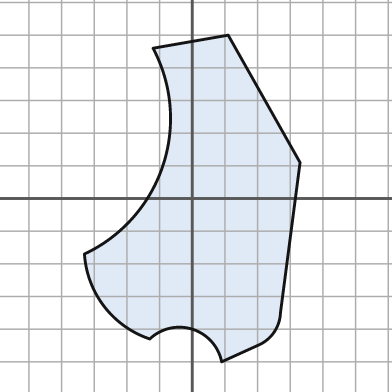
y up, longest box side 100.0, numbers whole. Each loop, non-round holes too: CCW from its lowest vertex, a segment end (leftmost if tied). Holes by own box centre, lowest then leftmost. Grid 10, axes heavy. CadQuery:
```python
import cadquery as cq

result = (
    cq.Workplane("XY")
    .moveTo(9.0, -50.0)
    .lineTo(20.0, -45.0)
    .threePointArc((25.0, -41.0), (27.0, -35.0))
    .lineTo(33.0, 11.0)
    .lineTo(11.0, 50.0)
    .lineTo(-12.0, 46.0)
    .threePointArc((-9.0, 10.0), (-33.0, -17.0))
    .threePointArc((-27.0, -33.0), (-13.0, -43.0))
    .threePointArc((0.0, -40.0), (9.0, -50.0))
    .close()
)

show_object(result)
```